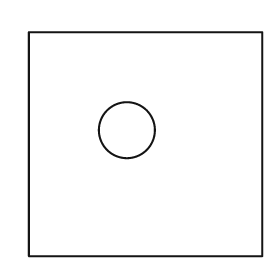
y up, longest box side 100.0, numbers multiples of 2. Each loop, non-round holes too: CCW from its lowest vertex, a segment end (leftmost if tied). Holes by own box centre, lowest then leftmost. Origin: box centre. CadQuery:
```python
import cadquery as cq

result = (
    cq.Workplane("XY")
    .moveTo(-50.0, -48.0)
    .lineTo(50.0, -48.0)
    .lineTo(50.0, 48.0)
    .lineTo(-50.0, 48.0)
    .close()
    .moveTo(-8.0, 6.0)
    .circle(12.0)
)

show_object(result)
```